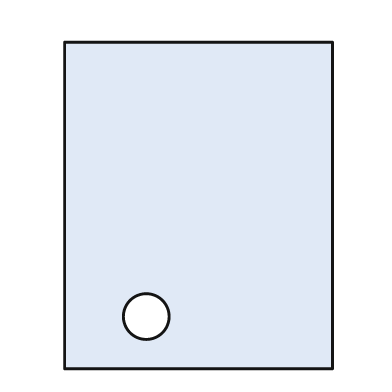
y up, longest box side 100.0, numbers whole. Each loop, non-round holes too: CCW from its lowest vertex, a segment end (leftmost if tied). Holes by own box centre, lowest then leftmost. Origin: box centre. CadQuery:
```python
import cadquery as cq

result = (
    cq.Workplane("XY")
    .moveTo(-41.0, -50.0)
    .lineTo(41.0, -50.0)
    .lineTo(41.0, 50.0)
    .lineTo(-41.0, 50.0)
    .close()
    .moveTo(-16.0, -34.0)
    .circle(7.0)
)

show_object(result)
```